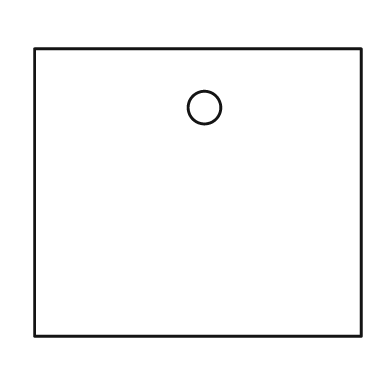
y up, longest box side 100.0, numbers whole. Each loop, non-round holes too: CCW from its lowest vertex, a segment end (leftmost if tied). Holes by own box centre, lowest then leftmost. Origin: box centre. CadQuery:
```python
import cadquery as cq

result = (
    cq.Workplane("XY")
    .moveTo(-50.0, -44.0)
    .lineTo(50.0, -44.0)
    .lineTo(50.0, 44.0)
    .lineTo(-50.0, 44.0)
    .close()
    .moveTo(2.0, 26.0)
    .circle(5.0)
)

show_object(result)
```